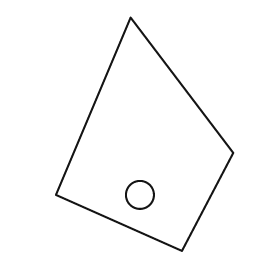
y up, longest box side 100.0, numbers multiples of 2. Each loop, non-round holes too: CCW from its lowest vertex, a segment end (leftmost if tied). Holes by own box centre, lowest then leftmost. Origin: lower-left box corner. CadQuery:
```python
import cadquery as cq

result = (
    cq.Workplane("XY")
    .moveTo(54.0, 0.0)
    .lineTo(76.0, 42.0)
    .lineTo(32.0, 100.0)
    .lineTo(0.0, 24.0)
    .close()
    .moveTo(36.0, 24.0)
    .circle(6.0)
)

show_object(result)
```